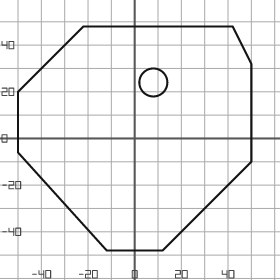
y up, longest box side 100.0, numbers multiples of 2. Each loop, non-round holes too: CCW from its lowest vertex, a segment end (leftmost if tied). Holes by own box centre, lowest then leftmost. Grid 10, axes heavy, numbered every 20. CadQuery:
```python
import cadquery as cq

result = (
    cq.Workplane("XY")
    .moveTo(-12.0, -48.0)
    .lineTo(12.0, -48.0)
    .lineTo(50.0, -10.0)
    .lineTo(50.0, 32.0)
    .lineTo(42.0, 48.0)
    .lineTo(-22.0, 48.0)
    .lineTo(-50.0, 20.0)
    .lineTo(-50.0, -6.0)
    .close()
    .moveTo(8.0, 24.0)
    .circle(6.0)
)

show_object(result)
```